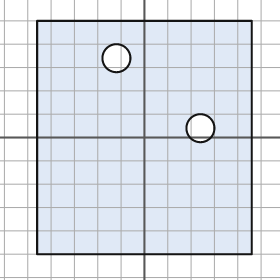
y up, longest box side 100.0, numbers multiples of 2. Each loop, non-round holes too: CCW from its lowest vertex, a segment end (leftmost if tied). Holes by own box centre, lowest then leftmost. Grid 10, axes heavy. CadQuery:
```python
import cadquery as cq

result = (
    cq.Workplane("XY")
    .moveTo(-46.0, -50.0)
    .lineTo(46.0, -50.0)
    .lineTo(46.0, 50.0)
    .lineTo(-46.0, 50.0)
    .close()
    .moveTo(24.0, 4.0)
    .circle(6.0)
    .moveTo(-12.0, 34.0)
    .circle(6.0)
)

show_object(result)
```